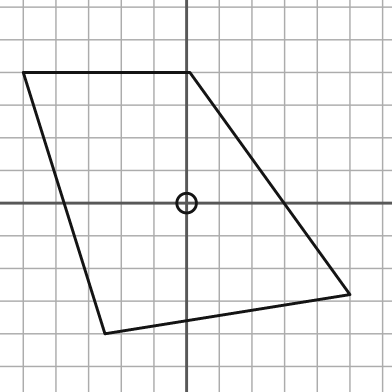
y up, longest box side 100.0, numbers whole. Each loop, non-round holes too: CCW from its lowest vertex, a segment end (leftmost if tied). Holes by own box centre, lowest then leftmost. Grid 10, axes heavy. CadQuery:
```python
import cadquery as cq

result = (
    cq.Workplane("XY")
    .moveTo(-25.0, -40.0)
    .lineTo(50.0, -28.0)
    .lineTo(1.0, 40.0)
    .lineTo(-50.0, 40.0)
    .close()
    .moveTo(0.0, 0.0)
    .circle(3.0)
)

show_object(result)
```